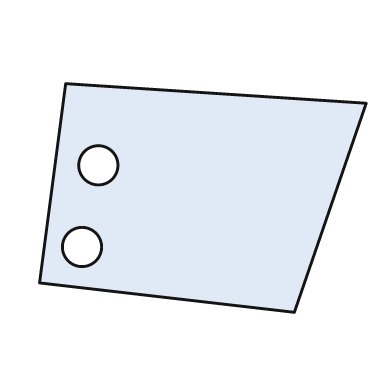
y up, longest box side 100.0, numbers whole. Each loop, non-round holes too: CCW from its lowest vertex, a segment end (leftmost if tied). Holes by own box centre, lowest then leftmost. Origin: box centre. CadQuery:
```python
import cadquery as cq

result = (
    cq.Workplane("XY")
    .moveTo(28.0, -35.0)
    .lineTo(50.0, 29.0)
    .lineTo(-42.0, 35.0)
    .lineTo(-50.0, -26.0)
    .close()
    .moveTo(-37.0, -15.0)
    .circle(6.0)
    .moveTo(-32.0, 10.0)
    .circle(6.0)
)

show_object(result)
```